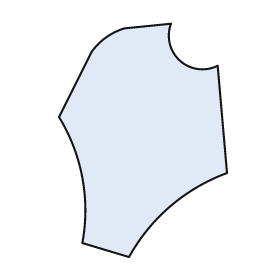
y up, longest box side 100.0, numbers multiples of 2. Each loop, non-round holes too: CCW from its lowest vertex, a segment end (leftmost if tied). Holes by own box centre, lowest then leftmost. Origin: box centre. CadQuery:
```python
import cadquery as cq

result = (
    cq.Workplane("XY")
    .moveTo(-6.0, -50.0)
    .threePointArc((12.0, -28.0), (36.0, -14.0))
    .lineTo(32.0, 32.0)
    .threePointArc((16.0, 34.0), (12.0, 50.0))
    .lineTo(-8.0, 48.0)
    .threePointArc((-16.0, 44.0), (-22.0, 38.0))
    .lineTo(-36.0, 10.0)
    .threePointArc((-26.0, -16.0), (-26.0, -44.0))
    .close()
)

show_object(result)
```